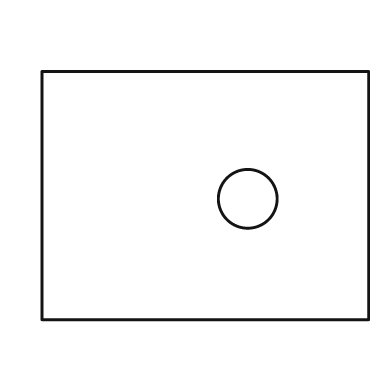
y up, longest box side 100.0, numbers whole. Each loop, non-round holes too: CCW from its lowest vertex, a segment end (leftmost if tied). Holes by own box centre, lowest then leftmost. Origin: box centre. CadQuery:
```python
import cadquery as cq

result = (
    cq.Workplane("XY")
    .moveTo(-50.0, -38.0)
    .lineTo(50.0, -38.0)
    .lineTo(50.0, 38.0)
    .lineTo(-50.0, 38.0)
    .close()
    .moveTo(13.0, -1.0)
    .circle(9.0)
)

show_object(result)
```